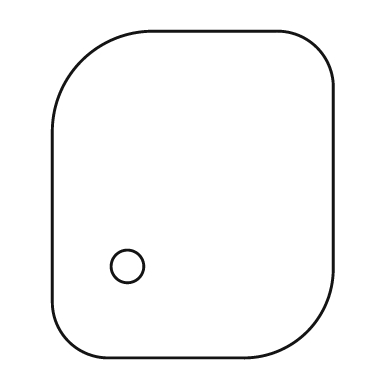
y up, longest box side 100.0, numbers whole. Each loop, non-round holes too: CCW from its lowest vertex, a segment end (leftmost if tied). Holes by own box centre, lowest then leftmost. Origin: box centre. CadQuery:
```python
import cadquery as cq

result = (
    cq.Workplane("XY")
    .moveTo(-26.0, -50.0)
    .lineTo(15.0, -50.0)
    .threePointArc((35.0, -42.0), (43.0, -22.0))
    .lineTo(43.0, 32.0)
    .threePointArc((38.0, 45.0), (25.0, 50.0))
    .lineTo(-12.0, 50.0)
    .threePointArc((-34.0, 41.0), (-43.0, 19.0))
    .lineTo(-43.0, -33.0)
    .threePointArc((-38.0, -45.0), (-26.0, -50.0))
    .close()
    .moveTo(-20.0, -22.0)
    .circle(5.0)
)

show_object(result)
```